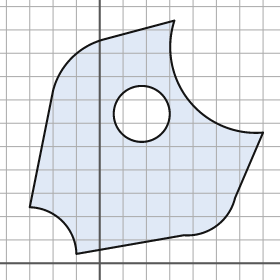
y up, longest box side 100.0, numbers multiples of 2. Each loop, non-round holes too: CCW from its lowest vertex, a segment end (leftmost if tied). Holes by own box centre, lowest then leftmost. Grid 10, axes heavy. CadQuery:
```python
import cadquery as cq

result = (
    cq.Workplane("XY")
    .moveTo(-10.0, 4.0)
    .lineTo(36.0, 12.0)
    .threePointArc((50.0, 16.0), (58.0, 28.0))
    .lineTo(70.0, 56.0)
    .threePointArc((38.0, 70.0), (32.0, 104.0))
    .lineTo(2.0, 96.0)
    .threePointArc((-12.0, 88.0), (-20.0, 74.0))
    .lineTo(-30.0, 24.0)
    .threePointArc((-16.0, 18.0), (-10.0, 4.0))
    .close()
    .moveTo(18.0, 64.0)
    .circle(12.0)
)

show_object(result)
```